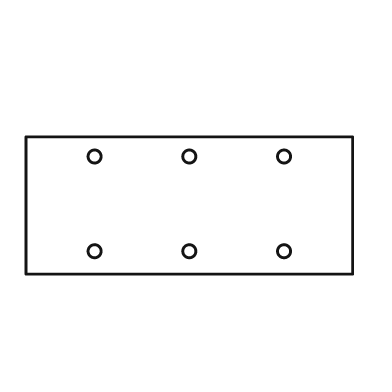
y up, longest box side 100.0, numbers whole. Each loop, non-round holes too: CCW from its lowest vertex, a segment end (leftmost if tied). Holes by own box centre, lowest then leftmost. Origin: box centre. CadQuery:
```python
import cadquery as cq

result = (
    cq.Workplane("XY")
    .moveTo(-50.0, -21.0)
    .lineTo(50.0, -21.0)
    .lineTo(50.0, 21.0)
    .lineTo(-50.0, 21.0)
    .close()
    .moveTo(-29.0, -14.0)
    .circle(2.0)
    .moveTo(0.0, -14.0)
    .circle(2.0)
    .moveTo(29.0, -14.0)
    .circle(2.0)
    .moveTo(-29.0, 15.0)
    .circle(2.0)
    .moveTo(0.0, 15.0)
    .circle(2.0)
    .moveTo(29.0, 15.0)
    .circle(2.0)
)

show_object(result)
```